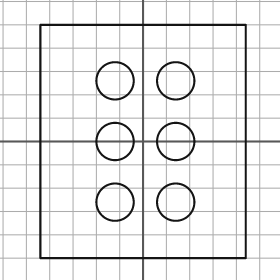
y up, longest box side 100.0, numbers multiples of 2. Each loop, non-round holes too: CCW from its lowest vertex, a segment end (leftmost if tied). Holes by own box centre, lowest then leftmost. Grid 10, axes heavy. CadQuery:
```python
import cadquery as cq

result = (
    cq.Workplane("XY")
    .moveTo(-44.0, -50.0)
    .lineTo(44.0, -50.0)
    .lineTo(44.0, 50.0)
    .lineTo(-44.0, 50.0)
    .close()
    .moveTo(-12.0, -26.0)
    .circle(8.0)
    .moveTo(14.0, -26.0)
    .circle(8.0)
    .moveTo(-12.0, 0.0)
    .circle(8.0)
    .moveTo(14.0, 0.0)
    .circle(8.0)
    .moveTo(-12.0, 26.0)
    .circle(8.0)
    .moveTo(14.0, 26.0)
    .circle(8.0)
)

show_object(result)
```